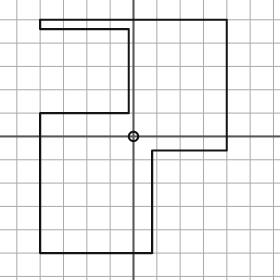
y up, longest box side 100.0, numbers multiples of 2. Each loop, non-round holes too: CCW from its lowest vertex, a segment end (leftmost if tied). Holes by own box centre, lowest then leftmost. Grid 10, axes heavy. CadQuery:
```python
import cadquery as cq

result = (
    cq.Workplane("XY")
    .moveTo(-40.0, -50.0)
    .lineTo(8.0, -50.0)
    .lineTo(8.0, -6.0)
    .lineTo(40.0, -6.0)
    .lineTo(40.0, 50.0)
    .lineTo(-40.0, 50.0)
    .lineTo(-40.0, 46.0)
    .lineTo(-2.0, 46.0)
    .lineTo(-2.0, 10.0)
    .lineTo(-40.0, 10.0)
    .close()
    .moveTo(0.0, 0.0)
    .circle(2.0)
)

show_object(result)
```